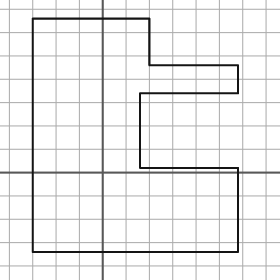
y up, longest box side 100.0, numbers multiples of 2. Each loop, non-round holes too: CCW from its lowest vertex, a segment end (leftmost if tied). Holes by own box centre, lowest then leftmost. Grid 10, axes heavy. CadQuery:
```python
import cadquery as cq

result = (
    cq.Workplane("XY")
    .moveTo(-30.0, -34.0)
    .lineTo(58.0, -34.0)
    .lineTo(58.0, 2.0)
    .lineTo(16.0, 2.0)
    .lineTo(16.0, 34.0)
    .lineTo(58.0, 34.0)
    .lineTo(58.0, 46.0)
    .lineTo(20.0, 46.0)
    .lineTo(20.0, 66.0)
    .lineTo(-30.0, 66.0)
    .close()
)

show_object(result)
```